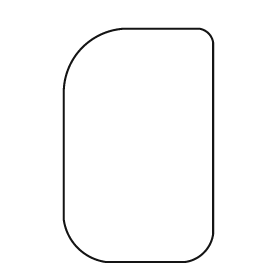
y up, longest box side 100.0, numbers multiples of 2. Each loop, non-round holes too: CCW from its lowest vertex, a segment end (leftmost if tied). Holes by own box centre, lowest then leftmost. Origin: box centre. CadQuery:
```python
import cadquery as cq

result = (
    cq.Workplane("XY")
    .moveTo(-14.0, -50.0)
    .lineTo(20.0, -50.0)
    .threePointArc((28.0, -46.0), (32.0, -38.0))
    .lineTo(32.0, 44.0)
    .threePointArc((30.0, 48.0), (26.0, 50.0))
    .lineTo(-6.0, 50.0)
    .threePointArc((-24.0, 42.0), (-32.0, 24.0))
    .lineTo(-32.0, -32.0)
    .threePointArc((-26.0, -44.0), (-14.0, -50.0))
    .close()
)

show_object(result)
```